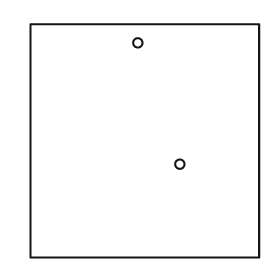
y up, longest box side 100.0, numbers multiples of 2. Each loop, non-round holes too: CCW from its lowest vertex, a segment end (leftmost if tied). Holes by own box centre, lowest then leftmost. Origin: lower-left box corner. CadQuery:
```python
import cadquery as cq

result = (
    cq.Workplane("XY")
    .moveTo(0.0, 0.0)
    .lineTo(98.0, 0.0)
    .lineTo(98.0, 100.0)
    .lineTo(0.0, 100.0)
    .close()
    .moveTo(64.0, 40.0)
    .circle(2.0)
    .moveTo(46.0, 92.0)
    .circle(2.0)
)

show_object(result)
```